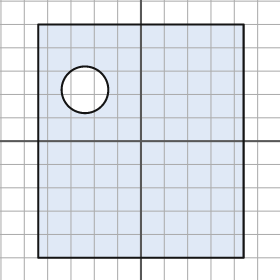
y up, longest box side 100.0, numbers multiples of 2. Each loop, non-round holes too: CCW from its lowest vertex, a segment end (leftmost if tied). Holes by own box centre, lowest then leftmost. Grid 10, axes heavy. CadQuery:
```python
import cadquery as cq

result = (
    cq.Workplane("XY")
    .moveTo(-44.0, -50.0)
    .lineTo(44.0, -50.0)
    .lineTo(44.0, 50.0)
    .lineTo(-44.0, 50.0)
    .close()
    .moveTo(-24.0, 22.0)
    .circle(10.0)
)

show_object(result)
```